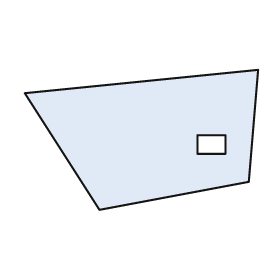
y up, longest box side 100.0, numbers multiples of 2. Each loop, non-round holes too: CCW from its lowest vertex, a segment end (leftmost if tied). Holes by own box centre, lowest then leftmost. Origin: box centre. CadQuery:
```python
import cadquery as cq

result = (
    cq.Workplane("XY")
    .moveTo(-18.0, -30.0)
    .lineTo(46.0, -18.0)
    .lineTo(50.0, 30.0)
    .lineTo(-50.0, 20.0)
    .close()
    .moveTo(24.0, -6.0)
    .lineTo(36.0, -6.0)
    .lineTo(36.0, 2.0)
    .lineTo(24.0, 2.0)
    .close()
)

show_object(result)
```